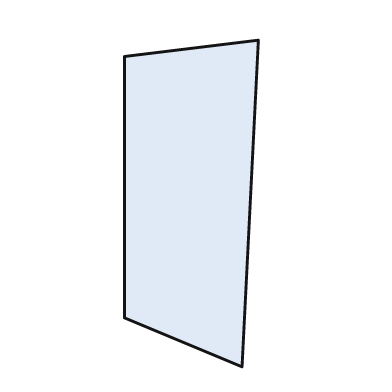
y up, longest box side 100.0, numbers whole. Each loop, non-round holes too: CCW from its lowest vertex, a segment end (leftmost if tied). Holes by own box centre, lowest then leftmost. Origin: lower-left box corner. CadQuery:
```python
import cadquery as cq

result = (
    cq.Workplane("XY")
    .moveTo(36.0, 0.0)
    .lineTo(41.0, 100.0)
    .lineTo(0.0, 95.0)
    .lineTo(0.0, 15.0)
    .close()
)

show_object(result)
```